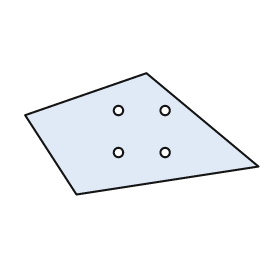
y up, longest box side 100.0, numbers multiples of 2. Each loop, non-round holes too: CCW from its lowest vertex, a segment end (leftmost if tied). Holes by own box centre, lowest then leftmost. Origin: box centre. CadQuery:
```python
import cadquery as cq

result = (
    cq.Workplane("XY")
    .moveTo(-28.0, -26.0)
    .lineTo(50.0, -14.0)
    .lineTo(2.0, 26.0)
    .lineTo(-50.0, 8.0)
    .close()
    .moveTo(-10.0, -8.0)
    .circle(2.0)
    .moveTo(10.0, -8.0)
    .circle(2.0)
    .moveTo(-10.0, 10.0)
    .circle(2.0)
    .moveTo(10.0, 10.0)
    .circle(2.0)
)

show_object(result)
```